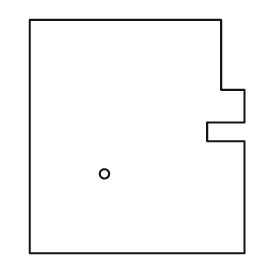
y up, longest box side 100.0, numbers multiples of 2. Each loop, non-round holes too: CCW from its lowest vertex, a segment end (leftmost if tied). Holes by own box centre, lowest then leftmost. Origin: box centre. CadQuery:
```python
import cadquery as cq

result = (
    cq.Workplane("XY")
    .moveTo(-46.0, -50.0)
    .lineTo(46.0, -50.0)
    .lineTo(46.0, -2.0)
    .lineTo(30.0, -2.0)
    .lineTo(30.0, 6.0)
    .lineTo(46.0, 6.0)
    .lineTo(46.0, 20.0)
    .lineTo(36.0, 20.0)
    .lineTo(36.0, 50.0)
    .lineTo(-46.0, 50.0)
    .close()
    .moveTo(-14.0, -16.0)
    .circle(2.0)
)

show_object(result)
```